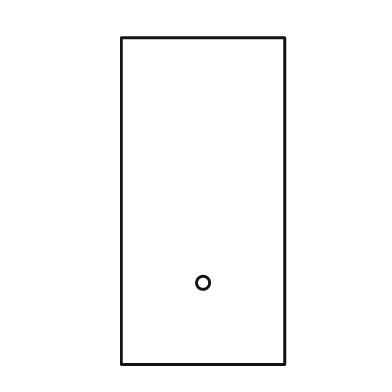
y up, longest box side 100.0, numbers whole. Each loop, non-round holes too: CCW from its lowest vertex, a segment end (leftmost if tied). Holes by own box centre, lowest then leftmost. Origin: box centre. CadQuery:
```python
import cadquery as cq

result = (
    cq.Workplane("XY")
    .moveTo(-25.0, -50.0)
    .lineTo(25.0, -50.0)
    .lineTo(25.0, 50.0)
    .lineTo(-25.0, 50.0)
    .close()
    .moveTo(0.0, -25.0)
    .circle(2.0)
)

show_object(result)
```